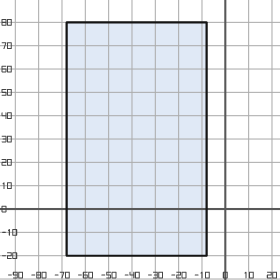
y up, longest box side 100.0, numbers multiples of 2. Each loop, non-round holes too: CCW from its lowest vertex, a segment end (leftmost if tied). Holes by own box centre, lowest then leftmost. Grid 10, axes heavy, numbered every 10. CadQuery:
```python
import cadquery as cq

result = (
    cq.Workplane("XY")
    .moveTo(-68.0, -20.0)
    .lineTo(-8.0, -20.0)
    .lineTo(-8.0, 80.0)
    .lineTo(-68.0, 80.0)
    .close()
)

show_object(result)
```